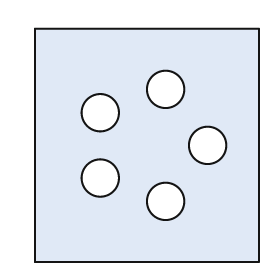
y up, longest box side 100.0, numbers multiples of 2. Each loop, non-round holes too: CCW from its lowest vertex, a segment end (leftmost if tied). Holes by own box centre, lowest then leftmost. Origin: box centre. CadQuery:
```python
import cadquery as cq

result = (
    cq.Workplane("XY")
    .moveTo(-48.0, -50.0)
    .lineTo(48.0, -50.0)
    .lineTo(48.0, 50.0)
    .lineTo(-48.0, 50.0)
    .close()
    .moveTo(8.0, -24.0)
    .circle(8.0)
    .moveTo(-20.0, -14.0)
    .circle(8.0)
    .moveTo(26.0, 0.0)
    .circle(8.0)
    .moveTo(-20.0, 14.0)
    .circle(8.0)
    .moveTo(8.0, 24.0)
    .circle(8.0)
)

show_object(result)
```